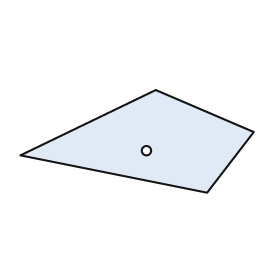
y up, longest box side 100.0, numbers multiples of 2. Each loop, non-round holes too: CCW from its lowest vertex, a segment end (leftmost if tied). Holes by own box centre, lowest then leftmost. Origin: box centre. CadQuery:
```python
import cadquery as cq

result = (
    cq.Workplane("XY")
    .moveTo(30.0, -22.0)
    .lineTo(50.0, 4.0)
    .lineTo(8.0, 22.0)
    .lineTo(-50.0, -6.0)
    .close()
    .moveTo(4.0, -4.0)
    .circle(2.0)
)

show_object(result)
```